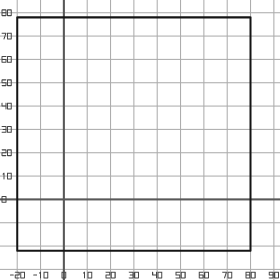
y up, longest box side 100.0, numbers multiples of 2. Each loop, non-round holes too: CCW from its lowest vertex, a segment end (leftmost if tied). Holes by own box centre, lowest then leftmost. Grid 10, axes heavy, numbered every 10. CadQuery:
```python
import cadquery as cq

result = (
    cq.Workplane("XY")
    .moveTo(-20.0, -22.0)
    .lineTo(80.0, -22.0)
    .lineTo(80.0, 78.0)
    .lineTo(-20.0, 78.0)
    .close()
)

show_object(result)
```